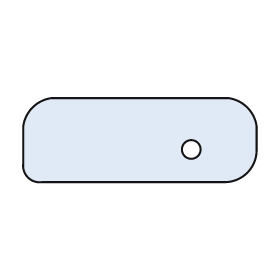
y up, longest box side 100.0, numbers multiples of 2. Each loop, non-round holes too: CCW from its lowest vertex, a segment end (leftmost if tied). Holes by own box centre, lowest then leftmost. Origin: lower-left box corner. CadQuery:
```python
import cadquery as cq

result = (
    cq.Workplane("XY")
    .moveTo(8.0, 0.0)
    .lineTo(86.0, 0.0)
    .threePointArc((96.0, 4.0), (100.0, 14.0))
    .lineTo(100.0, 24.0)
    .threePointArc((96.0, 32.0), (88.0, 36.0))
    .lineTo(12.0, 36.0)
    .threePointArc((4.0, 32.0), (0.0, 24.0))
    .lineTo(0.0, 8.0)
    .threePointArc((2.0, 2.0), (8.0, 0.0))
    .close()
    .moveTo(72.0, 14.0)
    .circle(4.0)
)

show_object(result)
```